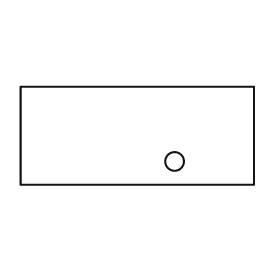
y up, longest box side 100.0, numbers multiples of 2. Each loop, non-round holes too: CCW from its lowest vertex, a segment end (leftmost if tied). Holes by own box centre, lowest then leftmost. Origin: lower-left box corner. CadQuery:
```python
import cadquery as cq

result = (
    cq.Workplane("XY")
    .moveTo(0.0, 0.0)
    .lineTo(100.0, 0.0)
    .lineTo(100.0, 42.0)
    .lineTo(0.0, 42.0)
    .close()
    .moveTo(66.0, 10.0)
    .circle(4.0)
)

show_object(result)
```